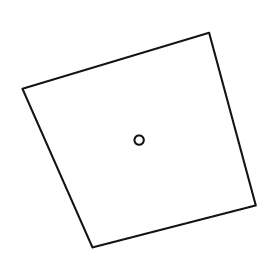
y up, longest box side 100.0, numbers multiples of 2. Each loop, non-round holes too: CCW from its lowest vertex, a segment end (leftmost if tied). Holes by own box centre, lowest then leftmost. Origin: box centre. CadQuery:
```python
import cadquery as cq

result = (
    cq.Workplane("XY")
    .moveTo(-20.0, -46.0)
    .lineTo(50.0, -28.0)
    .lineTo(30.0, 46.0)
    .lineTo(-50.0, 22.0)
    .close()
    .moveTo(0.0, 0.0)
    .circle(2.0)
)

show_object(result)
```